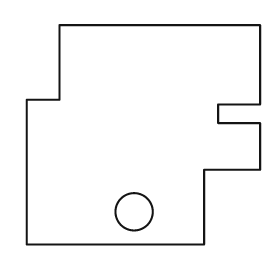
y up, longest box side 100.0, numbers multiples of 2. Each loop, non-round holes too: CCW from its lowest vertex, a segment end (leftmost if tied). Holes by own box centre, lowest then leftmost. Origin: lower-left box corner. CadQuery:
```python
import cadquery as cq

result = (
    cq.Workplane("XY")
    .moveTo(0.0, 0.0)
    .lineTo(76.0, 0.0)
    .lineTo(76.0, 32.0)
    .lineTo(100.0, 32.0)
    .lineTo(100.0, 52.0)
    .lineTo(82.0, 52.0)
    .lineTo(82.0, 60.0)
    .lineTo(100.0, 60.0)
    .lineTo(100.0, 94.0)
    .lineTo(14.0, 94.0)
    .lineTo(14.0, 62.0)
    .lineTo(0.0, 62.0)
    .close()
    .moveTo(46.0, 14.0)
    .circle(8.0)
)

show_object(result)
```